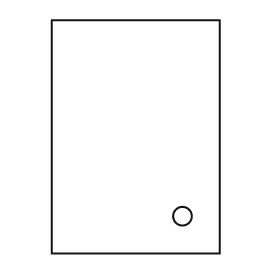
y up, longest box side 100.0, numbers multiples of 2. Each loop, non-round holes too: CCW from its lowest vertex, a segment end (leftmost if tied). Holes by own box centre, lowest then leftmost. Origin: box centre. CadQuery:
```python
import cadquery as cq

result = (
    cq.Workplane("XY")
    .moveTo(-36.0, -50.0)
    .lineTo(36.0, -50.0)
    .lineTo(36.0, 50.0)
    .lineTo(-36.0, 50.0)
    .close()
    .moveTo(20.0, -34.0)
    .circle(4.0)
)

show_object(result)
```